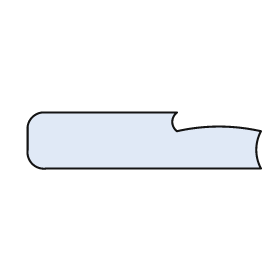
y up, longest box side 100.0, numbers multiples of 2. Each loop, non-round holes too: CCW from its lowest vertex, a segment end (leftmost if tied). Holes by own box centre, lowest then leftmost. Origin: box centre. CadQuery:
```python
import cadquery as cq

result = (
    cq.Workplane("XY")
    .moveTo(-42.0, -12.0)
    .lineTo(50.0, -12.0)
    .threePointArc((48.0, -4.0), (50.0, 4.0))
    .threePointArc((32.0, 6.0), (14.0, 4.0))
    .threePointArc((12.0, 8.0), (14.0, 12.0))
    .lineTo(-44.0, 12.0)
    .threePointArc((-48.0, 10.0), (-50.0, 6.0))
    .lineTo(-50.0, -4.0)
    .threePointArc((-48.0, -10.0), (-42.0, -12.0))
    .close()
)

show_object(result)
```